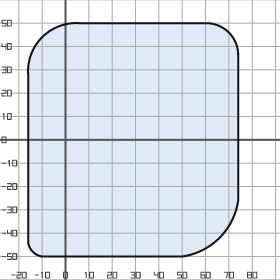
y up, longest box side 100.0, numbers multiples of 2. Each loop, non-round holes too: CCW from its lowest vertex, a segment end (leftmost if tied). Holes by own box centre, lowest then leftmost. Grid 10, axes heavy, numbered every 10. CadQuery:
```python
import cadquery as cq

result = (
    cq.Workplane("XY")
    .moveTo(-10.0, -50.0)
    .lineTo(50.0, -50.0)
    .threePointArc((66.0, -42.0), (74.0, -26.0))
    .lineTo(74.0, 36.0)
    .threePointArc((70.0, 46.0), (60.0, 50.0))
    .lineTo(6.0, 50.0)
    .threePointArc((-10.0, 44.0), (-16.0, 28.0))
    .lineTo(-16.0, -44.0)
    .threePointArc((-14.0, -48.0), (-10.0, -50.0))
    .close()
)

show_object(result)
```